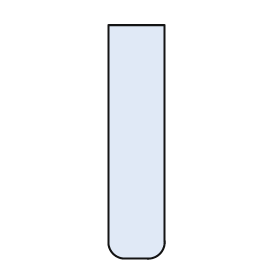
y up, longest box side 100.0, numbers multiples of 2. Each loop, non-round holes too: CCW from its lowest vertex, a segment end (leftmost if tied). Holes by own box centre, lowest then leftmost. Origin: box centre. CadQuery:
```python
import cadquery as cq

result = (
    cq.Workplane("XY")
    .moveTo(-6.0, -50.0)
    .lineTo(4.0, -50.0)
    .threePointArc((10.0, -48.0), (12.0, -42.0))
    .lineTo(12.0, 50.0)
    .lineTo(-12.0, 50.0)
    .lineTo(-12.0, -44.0)
    .threePointArc((-10.0, -48.0), (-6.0, -50.0))
    .close()
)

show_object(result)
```